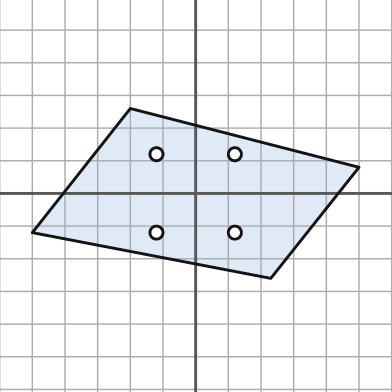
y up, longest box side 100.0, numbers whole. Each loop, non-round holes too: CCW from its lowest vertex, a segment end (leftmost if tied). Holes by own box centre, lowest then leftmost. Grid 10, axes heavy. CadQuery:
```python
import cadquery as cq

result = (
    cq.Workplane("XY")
    .moveTo(23.0, -26.0)
    .lineTo(50.0, 8.0)
    .lineTo(-20.0, 26.0)
    .lineTo(-50.0, -12.0)
    .close()
    .moveTo(-12.0, -12.0)
    .circle(2.0)
    .moveTo(12.0, -12.0)
    .circle(2.0)
    .moveTo(-12.0, 12.0)
    .circle(2.0)
    .moveTo(12.0, 12.0)
    .circle(2.0)
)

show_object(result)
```